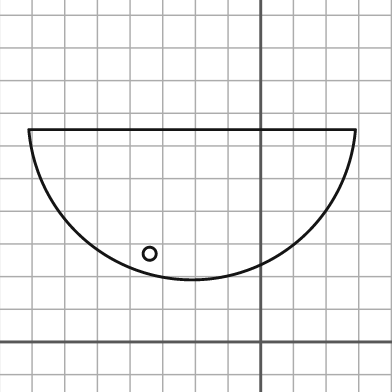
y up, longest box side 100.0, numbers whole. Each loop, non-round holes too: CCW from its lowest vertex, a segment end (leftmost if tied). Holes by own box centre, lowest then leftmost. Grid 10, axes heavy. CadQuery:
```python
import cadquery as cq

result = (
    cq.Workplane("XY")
    .moveTo(-71.0, 65.0)
    .threePointArc((-21.0, 19.0), (29.0, 65.0))
    .close()
    .moveTo(-34.0, 27.0)
    .circle(2.0)
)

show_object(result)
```